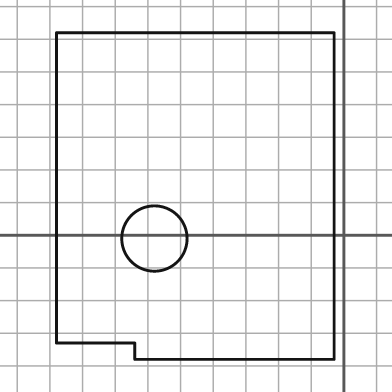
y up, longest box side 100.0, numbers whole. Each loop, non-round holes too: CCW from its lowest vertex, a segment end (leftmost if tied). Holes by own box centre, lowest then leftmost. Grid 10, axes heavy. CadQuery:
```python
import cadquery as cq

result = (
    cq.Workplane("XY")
    .moveTo(-64.0, -38.0)
    .lineTo(-3.0, -38.0)
    .lineTo(-3.0, 62.0)
    .lineTo(-88.0, 62.0)
    .lineTo(-88.0, -33.0)
    .lineTo(-64.0, -33.0)
    .close()
    .moveTo(-58.0, -1.0)
    .circle(10.0)
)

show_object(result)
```